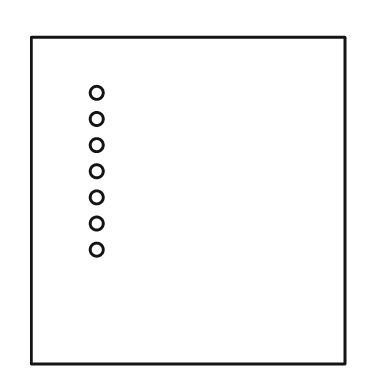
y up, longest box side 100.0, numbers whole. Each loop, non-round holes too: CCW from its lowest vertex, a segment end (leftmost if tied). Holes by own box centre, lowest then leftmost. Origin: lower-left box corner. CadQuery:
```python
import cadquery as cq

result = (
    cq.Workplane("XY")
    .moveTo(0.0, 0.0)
    .lineTo(96.0, 0.0)
    .lineTo(96.0, 100.0)
    .lineTo(0.0, 100.0)
    .close()
    .moveTo(20.0, 35.0)
    .circle(2.0)
    .moveTo(20.0, 43.0)
    .circle(2.0)
    .moveTo(20.0, 51.0)
    .circle(2.0)
    .moveTo(20.0, 59.0)
    .circle(2.0)
    .moveTo(20.0, 67.0)
    .circle(2.0)
    .moveTo(20.0, 75.0)
    .circle(2.0)
    .moveTo(20.0, 83.0)
    .circle(2.0)
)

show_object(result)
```